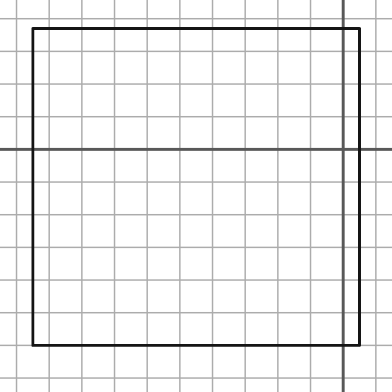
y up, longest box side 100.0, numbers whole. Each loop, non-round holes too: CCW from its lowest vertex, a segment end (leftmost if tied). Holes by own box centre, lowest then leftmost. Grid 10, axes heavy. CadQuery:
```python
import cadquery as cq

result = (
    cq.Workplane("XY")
    .moveTo(-95.0, -60.0)
    .lineTo(5.0, -60.0)
    .lineTo(5.0, 37.0)
    .lineTo(-95.0, 37.0)
    .close()
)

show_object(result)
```